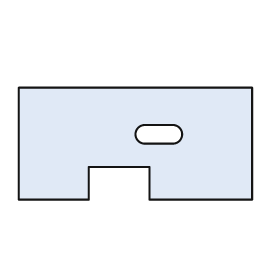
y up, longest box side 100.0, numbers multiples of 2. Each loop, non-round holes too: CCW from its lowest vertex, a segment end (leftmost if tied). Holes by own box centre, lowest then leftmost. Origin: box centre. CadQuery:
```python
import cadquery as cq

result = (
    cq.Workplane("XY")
    .moveTo(-50.0, -24.0)
    .lineTo(-20.0, -24.0)
    .lineTo(-20.0, -10.0)
    .lineTo(6.0, -10.0)
    .lineTo(6.0, -24.0)
    .lineTo(50.0, -24.0)
    .lineTo(50.0, 24.0)
    .lineTo(-50.0, 24.0)
    .close()
    .moveTo(4.0, 0.0)
    .lineTo(16.0, 0.0)
    .threePointArc((20.0, 4.0), (16.0, 8.0))
    .lineTo(4.0, 8.0)
    .threePointArc((0.0, 4.0), (4.0, 0.0))
    .close()
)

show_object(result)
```